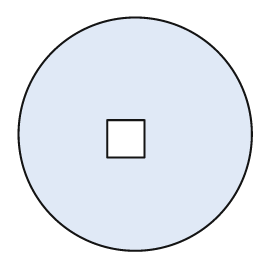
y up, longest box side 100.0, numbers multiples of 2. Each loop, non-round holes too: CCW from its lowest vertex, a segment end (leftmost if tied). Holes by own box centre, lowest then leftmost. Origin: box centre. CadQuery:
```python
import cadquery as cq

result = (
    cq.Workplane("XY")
    .moveTo(0.0, 0.0)
    .circle(50.0)
    .moveTo(-12.0, -10.0)
    .lineTo(4.0, -10.0)
    .lineTo(4.0, 6.0)
    .lineTo(-12.0, 6.0)
    .close()
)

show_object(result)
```